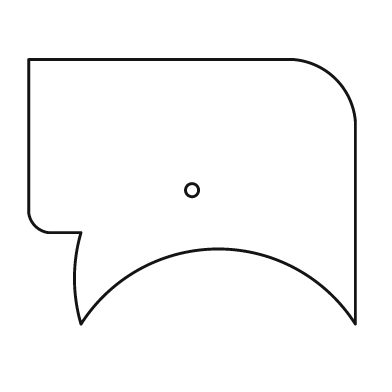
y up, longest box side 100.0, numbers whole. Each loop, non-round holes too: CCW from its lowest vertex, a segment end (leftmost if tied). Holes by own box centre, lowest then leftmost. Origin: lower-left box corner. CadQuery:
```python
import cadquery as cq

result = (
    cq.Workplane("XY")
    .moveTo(16.0, 0.0)
    .threePointArc((58.0, 23.0), (100.0, 0.0))
    .lineTo(100.0, 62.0)
    .threePointArc((94.0, 75.0), (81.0, 81.0))
    .lineTo(0.0, 81.0)
    .lineTo(0.0, 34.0)
    .threePointArc((2.0, 30.0), (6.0, 28.0))
    .lineTo(16.0, 28.0)
    .threePointArc((14.0, 14.0), (16.0, 0.0))
    .close()
    .moveTo(50.0, 41.0)
    .circle(2.0)
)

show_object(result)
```